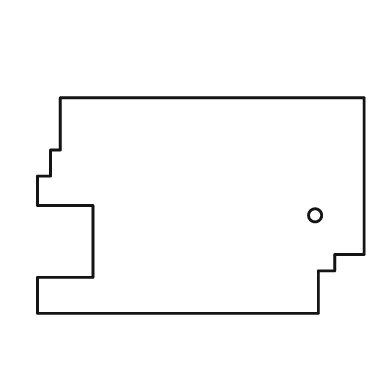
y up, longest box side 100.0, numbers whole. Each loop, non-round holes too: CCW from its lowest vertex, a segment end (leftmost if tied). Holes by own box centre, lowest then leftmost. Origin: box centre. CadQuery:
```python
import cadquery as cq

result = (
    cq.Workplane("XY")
    .moveTo(-50.0, -33.0)
    .lineTo(36.0, -33.0)
    .lineTo(36.0, -20.0)
    .lineTo(41.0, -20.0)
    .lineTo(41.0, -15.0)
    .lineTo(50.0, -15.0)
    .lineTo(50.0, 33.0)
    .lineTo(-43.0, 33.0)
    .lineTo(-43.0, 17.0)
    .lineTo(-46.0, 17.0)
    .lineTo(-46.0, 9.0)
    .lineTo(-50.0, 9.0)
    .lineTo(-50.0, 0.0)
    .lineTo(-33.0, 0.0)
    .lineTo(-33.0, -22.0)
    .lineTo(-50.0, -22.0)
    .close()
    .moveTo(35.0, -3.0)
    .circle(2.0)
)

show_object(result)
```